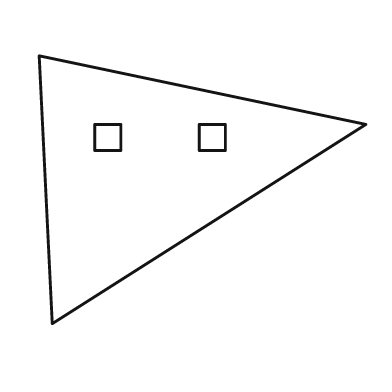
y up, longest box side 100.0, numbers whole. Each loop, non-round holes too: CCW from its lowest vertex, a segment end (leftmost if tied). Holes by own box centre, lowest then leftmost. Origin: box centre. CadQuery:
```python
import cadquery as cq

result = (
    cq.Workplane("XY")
    .moveTo(-46.0, -41.0)
    .lineTo(50.0, 20.0)
    .lineTo(-50.0, 41.0)
    .close()
    .moveTo(-33.0, 12.0)
    .lineTo(-25.0, 12.0)
    .lineTo(-25.0, 20.0)
    .lineTo(-33.0, 20.0)
    .close()
    .moveTo(-1.0, 12.0)
    .lineTo(7.0, 12.0)
    .lineTo(7.0, 20.0)
    .lineTo(-1.0, 20.0)
    .close()
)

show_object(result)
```